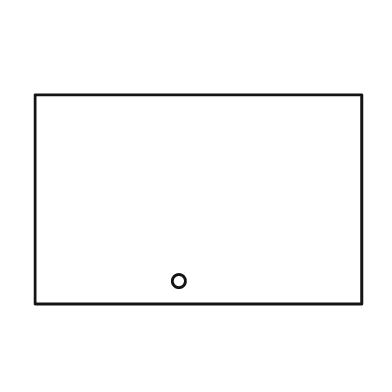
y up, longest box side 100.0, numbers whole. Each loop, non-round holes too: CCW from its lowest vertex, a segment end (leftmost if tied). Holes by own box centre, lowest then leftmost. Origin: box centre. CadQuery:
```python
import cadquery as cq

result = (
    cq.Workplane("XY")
    .moveTo(-50.0, -32.0)
    .lineTo(50.0, -32.0)
    .lineTo(50.0, 32.0)
    .lineTo(-50.0, 32.0)
    .close()
    .moveTo(-6.0, -25.0)
    .circle(2.0)
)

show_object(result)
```